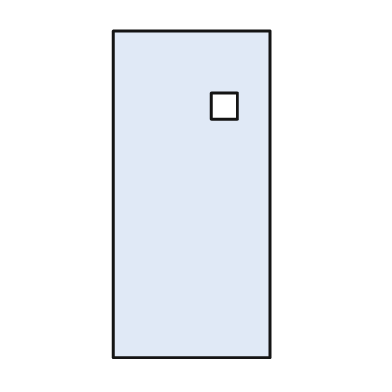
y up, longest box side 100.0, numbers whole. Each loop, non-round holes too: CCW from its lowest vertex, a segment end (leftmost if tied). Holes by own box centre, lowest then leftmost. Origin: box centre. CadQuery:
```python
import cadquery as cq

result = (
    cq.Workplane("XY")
    .moveTo(-24.0, -50.0)
    .lineTo(24.0, -50.0)
    .lineTo(24.0, 50.0)
    .lineTo(-24.0, 50.0)
    .close()
    .moveTo(6.0, 23.0)
    .lineTo(14.0, 23.0)
    .lineTo(14.0, 31.0)
    .lineTo(6.0, 31.0)
    .close()
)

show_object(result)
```